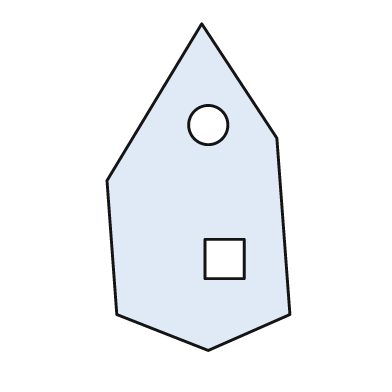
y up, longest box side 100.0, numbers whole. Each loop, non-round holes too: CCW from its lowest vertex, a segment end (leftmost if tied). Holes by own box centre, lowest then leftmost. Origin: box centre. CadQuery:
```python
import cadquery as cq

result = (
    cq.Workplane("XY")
    .moveTo(3.0, -50.0)
    .lineTo(28.0, -39.0)
    .lineTo(24.0, 15.0)
    .lineTo(1.0, 50.0)
    .lineTo(-28.0, 2.0)
    .lineTo(-25.0, -39.0)
    .close()
    .moveTo(2.0, -28.0)
    .lineTo(14.0, -28.0)
    .lineTo(14.0, -16.0)
    .lineTo(2.0, -16.0)
    .close()
    .moveTo(3.0, 19.0)
    .circle(6.0)
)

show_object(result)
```